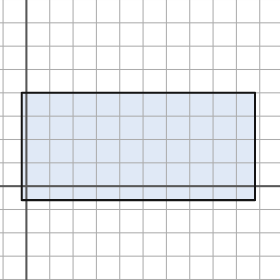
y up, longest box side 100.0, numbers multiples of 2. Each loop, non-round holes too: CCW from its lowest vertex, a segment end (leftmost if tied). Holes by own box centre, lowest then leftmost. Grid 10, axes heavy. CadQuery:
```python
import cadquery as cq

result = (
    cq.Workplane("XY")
    .moveTo(-2.0, -6.0)
    .lineTo(98.0, -6.0)
    .lineTo(98.0, 40.0)
    .lineTo(-2.0, 40.0)
    .close()
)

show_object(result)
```